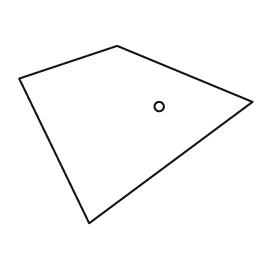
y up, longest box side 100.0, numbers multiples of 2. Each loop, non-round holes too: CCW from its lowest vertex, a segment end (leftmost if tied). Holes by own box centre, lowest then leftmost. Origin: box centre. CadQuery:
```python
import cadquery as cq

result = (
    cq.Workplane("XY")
    .moveTo(-20.0, -38.0)
    .lineTo(50.0, 14.0)
    .lineTo(-8.0, 38.0)
    .lineTo(-50.0, 24.0)
    .close()
    .moveTo(10.0, 12.0)
    .circle(2.0)
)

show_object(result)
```